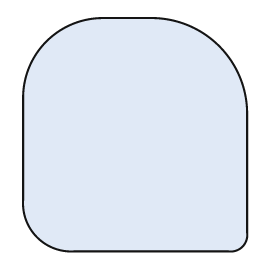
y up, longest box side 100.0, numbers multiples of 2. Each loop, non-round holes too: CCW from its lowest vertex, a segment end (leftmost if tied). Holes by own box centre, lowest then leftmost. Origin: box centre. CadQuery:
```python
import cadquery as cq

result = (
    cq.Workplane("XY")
    .moveTo(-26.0, -50.0)
    .lineTo(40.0, -50.0)
    .threePointArc((46.0, -48.0), (48.0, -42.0))
    .lineTo(48.0, 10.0)
    .threePointArc((36.0, 38.0), (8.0, 50.0))
    .lineTo(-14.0, 50.0)
    .threePointArc((-38.0, 40.0), (-48.0, 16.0))
    .lineTo(-48.0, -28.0)
    .threePointArc((-42.0, -44.0), (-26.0, -50.0))
    .close()
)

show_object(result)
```